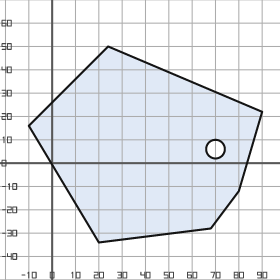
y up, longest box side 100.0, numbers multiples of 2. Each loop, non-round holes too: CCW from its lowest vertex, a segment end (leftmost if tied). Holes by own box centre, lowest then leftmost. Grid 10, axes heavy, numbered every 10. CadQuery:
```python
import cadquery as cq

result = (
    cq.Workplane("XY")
    .moveTo(20.0, -34.0)
    .lineTo(68.0, -28.0)
    .lineTo(80.0, -12.0)
    .lineTo(90.0, 22.0)
    .lineTo(24.0, 50.0)
    .lineTo(-10.0, 16.0)
    .close()
    .moveTo(70.0, 6.0)
    .circle(4.0)
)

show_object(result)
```